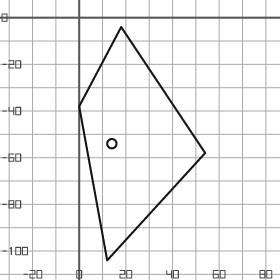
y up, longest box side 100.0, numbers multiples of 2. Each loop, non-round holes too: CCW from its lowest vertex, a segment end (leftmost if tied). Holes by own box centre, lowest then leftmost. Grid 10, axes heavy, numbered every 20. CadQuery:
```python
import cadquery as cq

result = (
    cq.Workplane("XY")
    .moveTo(12.0, -104.0)
    .lineTo(54.0, -58.0)
    .lineTo(18.0, -4.0)
    .lineTo(0.0, -38.0)
    .close()
    .moveTo(14.0, -54.0)
    .circle(2.0)
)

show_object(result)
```